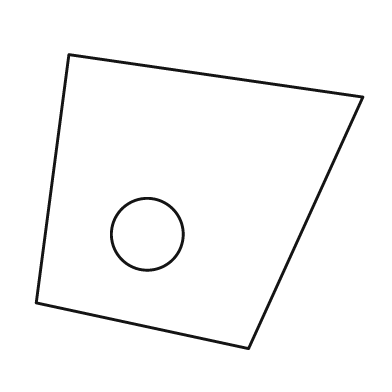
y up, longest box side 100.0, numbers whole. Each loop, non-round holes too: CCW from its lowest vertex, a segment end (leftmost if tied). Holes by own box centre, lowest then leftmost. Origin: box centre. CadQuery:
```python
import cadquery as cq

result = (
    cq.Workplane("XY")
    .moveTo(15.0, -45.0)
    .lineTo(50.0, 32.0)
    .lineTo(-40.0, 45.0)
    .lineTo(-50.0, -31.0)
    .close()
    .moveTo(-16.0, -10.0)
    .circle(11.0)
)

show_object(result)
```